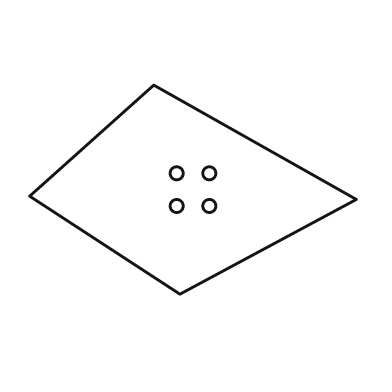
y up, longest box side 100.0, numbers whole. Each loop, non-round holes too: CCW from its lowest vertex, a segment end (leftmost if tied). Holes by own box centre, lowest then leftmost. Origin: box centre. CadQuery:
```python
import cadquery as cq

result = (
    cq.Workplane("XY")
    .moveTo(-4.0, -32.0)
    .lineTo(50.0, -3.0)
    .lineTo(-12.0, 32.0)
    .lineTo(-50.0, -2.0)
    .close()
    .moveTo(-5.0, -5.0)
    .circle(2.0)
    .moveTo(5.0, -5.0)
    .circle(2.0)
    .moveTo(-5.0, 5.0)
    .circle(2.0)
    .moveTo(5.0, 5.0)
    .circle(2.0)
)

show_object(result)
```